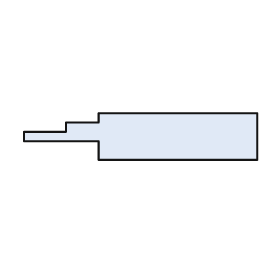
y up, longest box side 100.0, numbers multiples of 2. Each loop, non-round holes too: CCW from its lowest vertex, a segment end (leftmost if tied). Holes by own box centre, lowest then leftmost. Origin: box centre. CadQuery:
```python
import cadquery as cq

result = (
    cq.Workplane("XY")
    .moveTo(-18.0, -10.0)
    .lineTo(50.0, -10.0)
    .lineTo(50.0, 10.0)
    .lineTo(-18.0, 10.0)
    .lineTo(-18.0, 6.0)
    .lineTo(-32.0, 6.0)
    .lineTo(-32.0, 2.0)
    .lineTo(-50.0, 2.0)
    .lineTo(-50.0, -2.0)
    .lineTo(-18.0, -2.0)
    .close()
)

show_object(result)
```